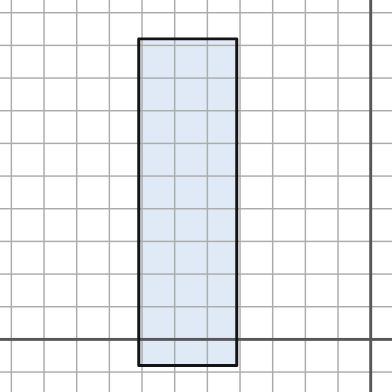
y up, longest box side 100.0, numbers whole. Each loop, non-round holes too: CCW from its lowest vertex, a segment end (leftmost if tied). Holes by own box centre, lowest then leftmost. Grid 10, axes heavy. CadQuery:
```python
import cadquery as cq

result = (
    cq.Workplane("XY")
    .moveTo(-71.0, -8.0)
    .lineTo(-41.0, -8.0)
    .lineTo(-41.0, 92.0)
    .lineTo(-71.0, 92.0)
    .close()
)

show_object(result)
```